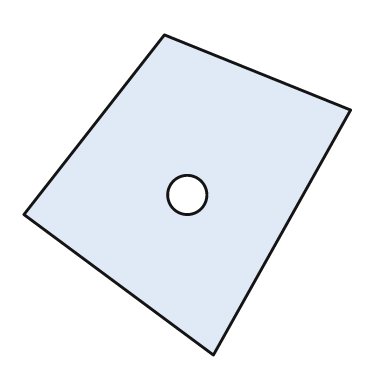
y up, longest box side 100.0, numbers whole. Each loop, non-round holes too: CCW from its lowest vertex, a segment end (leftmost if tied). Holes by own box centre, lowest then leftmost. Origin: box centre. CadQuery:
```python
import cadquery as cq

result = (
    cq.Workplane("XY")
    .moveTo(8.0, -49.0)
    .lineTo(50.0, 26.0)
    .lineTo(-7.0, 49.0)
    .lineTo(-50.0, -6.0)
    .close()
    .moveTo(0.0, 0.0)
    .circle(6.0)
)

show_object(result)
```